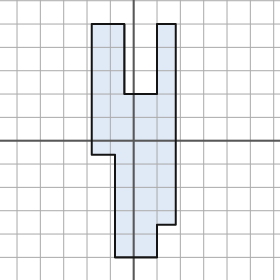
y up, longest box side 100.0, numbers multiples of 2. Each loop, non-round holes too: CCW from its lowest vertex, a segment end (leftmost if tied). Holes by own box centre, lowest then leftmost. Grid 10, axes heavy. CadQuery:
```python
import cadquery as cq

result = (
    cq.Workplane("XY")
    .moveTo(-8.0, -50.0)
    .lineTo(10.0, -50.0)
    .lineTo(10.0, -36.0)
    .lineTo(18.0, -36.0)
    .lineTo(18.0, 50.0)
    .lineTo(10.0, 50.0)
    .lineTo(10.0, 20.0)
    .lineTo(-4.0, 20.0)
    .lineTo(-4.0, 50.0)
    .lineTo(-18.0, 50.0)
    .lineTo(-18.0, -6.0)
    .lineTo(-8.0, -6.0)
    .close()
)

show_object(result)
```